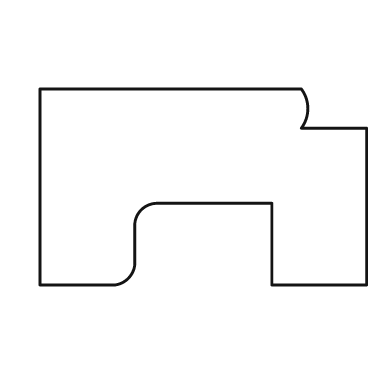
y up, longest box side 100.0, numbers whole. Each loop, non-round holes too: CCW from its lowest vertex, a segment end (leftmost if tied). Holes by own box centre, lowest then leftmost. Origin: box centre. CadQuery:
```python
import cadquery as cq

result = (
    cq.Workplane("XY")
    .moveTo(-50.0, -30.0)
    .lineTo(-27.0, -30.0)
    .threePointArc((-23.0, -28.0), (-21.0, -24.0))
    .lineTo(-21.0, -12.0)
    .threePointArc((-19.0, -7.0), (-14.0, -5.0))
    .lineTo(21.0, -5.0)
    .lineTo(21.0, -30.0)
    .lineTo(50.0, -30.0)
    .lineTo(50.0, 18.0)
    .lineTo(30.0, 18.0)
    .threePointArc((32.0, 24.0), (30.0, 30.0))
    .lineTo(-50.0, 30.0)
    .close()
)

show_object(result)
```